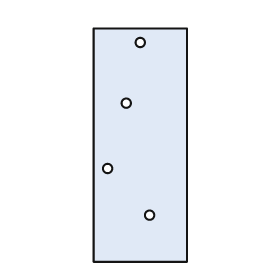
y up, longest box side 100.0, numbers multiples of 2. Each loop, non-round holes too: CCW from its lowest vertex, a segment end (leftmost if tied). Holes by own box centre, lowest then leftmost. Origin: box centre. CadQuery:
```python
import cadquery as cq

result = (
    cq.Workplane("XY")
    .moveTo(-20.0, -50.0)
    .lineTo(20.0, -50.0)
    .lineTo(20.0, 50.0)
    .lineTo(-20.0, 50.0)
    .close()
    .moveTo(4.0, -30.0)
    .circle(2.0)
    .moveTo(-14.0, -10.0)
    .circle(2.0)
    .moveTo(-6.0, 18.0)
    .circle(2.0)
    .moveTo(0.0, 44.0)
    .circle(2.0)
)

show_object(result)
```